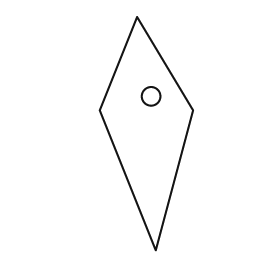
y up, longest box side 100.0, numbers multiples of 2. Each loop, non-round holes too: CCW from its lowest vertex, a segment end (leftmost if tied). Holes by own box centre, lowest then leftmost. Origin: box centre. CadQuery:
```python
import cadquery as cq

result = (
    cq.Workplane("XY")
    .moveTo(4.0, -50.0)
    .lineTo(20.0, 10.0)
    .lineTo(-4.0, 50.0)
    .lineTo(-20.0, 10.0)
    .close()
    .moveTo(2.0, 16.0)
    .circle(4.0)
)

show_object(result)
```